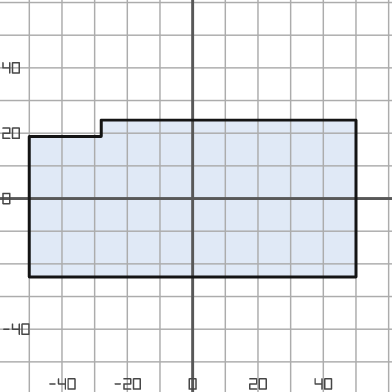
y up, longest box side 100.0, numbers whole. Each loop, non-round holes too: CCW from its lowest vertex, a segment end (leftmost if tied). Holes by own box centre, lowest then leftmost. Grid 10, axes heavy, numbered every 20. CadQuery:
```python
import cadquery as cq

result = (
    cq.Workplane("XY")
    .moveTo(-50.0, -24.0)
    .lineTo(50.0, -24.0)
    .lineTo(50.0, 24.0)
    .lineTo(-28.0, 24.0)
    .lineTo(-28.0, 19.0)
    .lineTo(-50.0, 19.0)
    .close()
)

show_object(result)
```